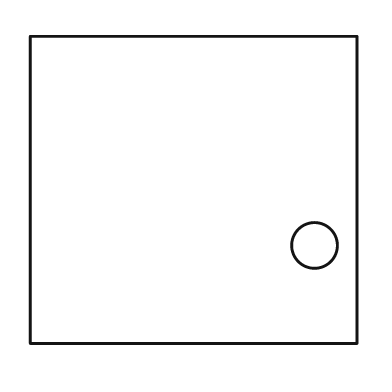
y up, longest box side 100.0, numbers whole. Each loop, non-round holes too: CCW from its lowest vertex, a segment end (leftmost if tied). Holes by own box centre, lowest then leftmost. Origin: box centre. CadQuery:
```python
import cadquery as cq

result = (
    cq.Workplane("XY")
    .moveTo(-50.0, -47.0)
    .lineTo(50.0, -47.0)
    .lineTo(50.0, 47.0)
    .lineTo(-50.0, 47.0)
    .close()
    .moveTo(37.0, -17.0)
    .circle(7.0)
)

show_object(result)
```